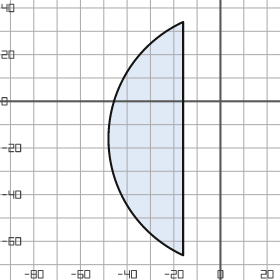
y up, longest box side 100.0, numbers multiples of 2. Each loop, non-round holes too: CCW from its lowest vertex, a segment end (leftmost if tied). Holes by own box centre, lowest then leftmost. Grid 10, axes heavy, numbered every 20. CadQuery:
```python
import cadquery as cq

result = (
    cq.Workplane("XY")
    .moveTo(-16.0, -66.0)
    .lineTo(-16.0, 34.0)
    .threePointArc((-48.0, -16.0), (-16.0, -66.0))
    .close()
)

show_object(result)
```